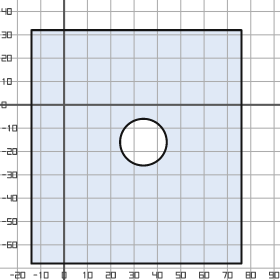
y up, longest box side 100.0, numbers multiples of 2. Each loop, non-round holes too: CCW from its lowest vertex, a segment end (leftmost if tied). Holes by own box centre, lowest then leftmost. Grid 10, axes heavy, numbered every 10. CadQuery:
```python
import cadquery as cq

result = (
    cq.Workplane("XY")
    .moveTo(-14.0, -68.0)
    .lineTo(76.0, -68.0)
    .lineTo(76.0, 32.0)
    .lineTo(-14.0, 32.0)
    .close()
    .moveTo(34.0, -16.0)
    .circle(10.0)
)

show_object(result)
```